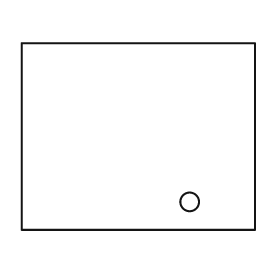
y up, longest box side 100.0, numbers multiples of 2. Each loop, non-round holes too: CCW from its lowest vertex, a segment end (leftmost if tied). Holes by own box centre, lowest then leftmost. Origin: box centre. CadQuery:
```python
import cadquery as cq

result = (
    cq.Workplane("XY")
    .moveTo(-50.0, -40.0)
    .lineTo(50.0, -40.0)
    .lineTo(50.0, 40.0)
    .lineTo(-50.0, 40.0)
    .close()
    .moveTo(22.0, -28.0)
    .circle(4.0)
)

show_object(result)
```